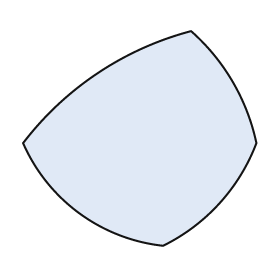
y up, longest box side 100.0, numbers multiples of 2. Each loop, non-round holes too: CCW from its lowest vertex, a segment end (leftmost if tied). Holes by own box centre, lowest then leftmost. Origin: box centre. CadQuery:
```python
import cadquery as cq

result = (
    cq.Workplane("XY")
    .moveTo(10.0, -46.0)
    .threePointArc((34.0, -28.0), (50.0, -2.0))
    .threePointArc((40.0, 24.0), (22.0, 46.0))
    .threePointArc((-18.0, 28.0), (-50.0, -2.0))
    .threePointArc((-26.0, -32.0), (10.0, -46.0))
    .close()
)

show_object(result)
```